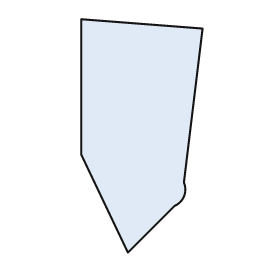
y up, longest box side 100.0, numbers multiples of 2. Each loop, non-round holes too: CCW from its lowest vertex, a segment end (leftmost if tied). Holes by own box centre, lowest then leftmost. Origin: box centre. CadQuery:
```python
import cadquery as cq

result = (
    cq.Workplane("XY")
    .moveTo(-6.0, -50.0)
    .lineTo(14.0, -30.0)
    .threePointArc((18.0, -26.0), (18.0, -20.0))
    .lineTo(26.0, 46.0)
    .lineTo(-26.0, 50.0)
    .lineTo(-26.0, -8.0)
    .close()
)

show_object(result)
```